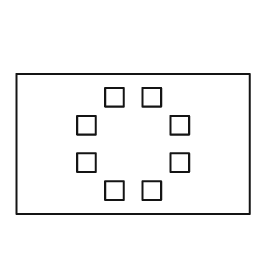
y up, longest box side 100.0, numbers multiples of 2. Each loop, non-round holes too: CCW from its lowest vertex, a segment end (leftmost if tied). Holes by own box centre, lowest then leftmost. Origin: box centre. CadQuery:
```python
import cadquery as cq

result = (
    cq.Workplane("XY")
    .moveTo(-50.0, -30.0)
    .lineTo(50.0, -30.0)
    .lineTo(50.0, 30.0)
    .lineTo(-50.0, 30.0)
    .close()
    .moveTo(-12.0, -24.0)
    .lineTo(-4.0, -24.0)
    .lineTo(-4.0, -16.0)
    .lineTo(-12.0, -16.0)
    .close()
    .moveTo(4.0, -24.0)
    .lineTo(12.0, -24.0)
    .lineTo(12.0, -16.0)
    .lineTo(4.0, -16.0)
    .close()
    .moveTo(-24.0, -12.0)
    .lineTo(-16.0, -12.0)
    .lineTo(-16.0, -4.0)
    .lineTo(-24.0, -4.0)
    .close()
    .moveTo(16.0, -12.0)
    .lineTo(24.0, -12.0)
    .lineTo(24.0, -4.0)
    .lineTo(16.0, -4.0)
    .close()
    .moveTo(-24.0, 4.0)
    .lineTo(-16.0, 4.0)
    .lineTo(-16.0, 12.0)
    .lineTo(-24.0, 12.0)
    .close()
    .moveTo(16.0, 4.0)
    .lineTo(24.0, 4.0)
    .lineTo(24.0, 12.0)
    .lineTo(16.0, 12.0)
    .close()
    .moveTo(-12.0, 16.0)
    .lineTo(-4.0, 16.0)
    .lineTo(-4.0, 24.0)
    .lineTo(-12.0, 24.0)
    .close()
    .moveTo(4.0, 16.0)
    .lineTo(12.0, 16.0)
    .lineTo(12.0, 24.0)
    .lineTo(4.0, 24.0)
    .close()
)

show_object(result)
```